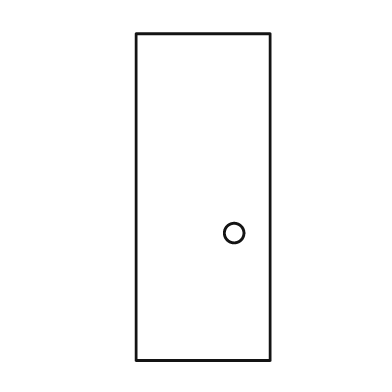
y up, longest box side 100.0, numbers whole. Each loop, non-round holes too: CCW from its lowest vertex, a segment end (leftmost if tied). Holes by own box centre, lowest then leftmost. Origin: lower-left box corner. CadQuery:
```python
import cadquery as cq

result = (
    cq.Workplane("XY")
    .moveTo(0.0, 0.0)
    .lineTo(41.0, 0.0)
    .lineTo(41.0, 100.0)
    .lineTo(0.0, 100.0)
    .close()
    .moveTo(30.0, 39.0)
    .circle(3.0)
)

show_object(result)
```